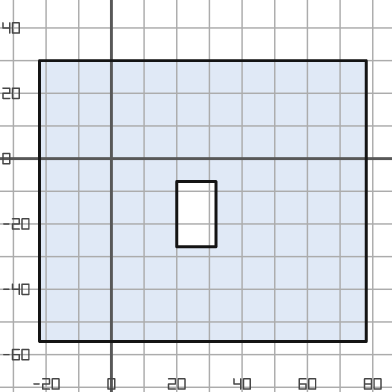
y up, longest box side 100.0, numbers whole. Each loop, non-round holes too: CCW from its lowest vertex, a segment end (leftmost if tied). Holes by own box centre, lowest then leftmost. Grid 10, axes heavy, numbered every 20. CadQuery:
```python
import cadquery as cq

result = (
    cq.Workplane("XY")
    .moveTo(-22.0, -56.0)
    .lineTo(78.0, -56.0)
    .lineTo(78.0, 30.0)
    .lineTo(-22.0, 30.0)
    .close()
    .moveTo(20.0, -27.0)
    .lineTo(32.0, -27.0)
    .lineTo(32.0, -7.0)
    .lineTo(20.0, -7.0)
    .close()
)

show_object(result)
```